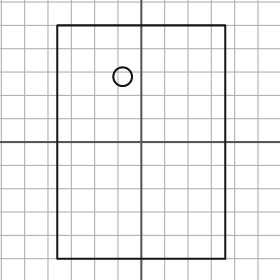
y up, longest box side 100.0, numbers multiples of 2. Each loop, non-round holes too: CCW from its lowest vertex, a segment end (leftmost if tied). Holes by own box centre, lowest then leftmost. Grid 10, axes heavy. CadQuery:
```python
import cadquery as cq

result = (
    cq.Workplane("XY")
    .moveTo(-36.0, -50.0)
    .lineTo(36.0, -50.0)
    .lineTo(36.0, 50.0)
    .lineTo(-36.0, 50.0)
    .close()
    .moveTo(-8.0, 28.0)
    .circle(4.0)
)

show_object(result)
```